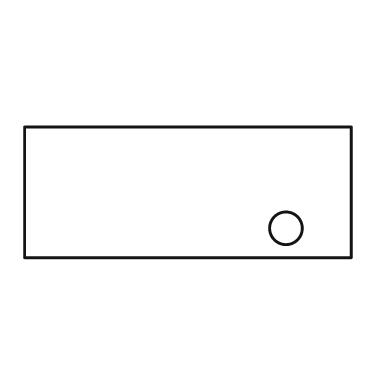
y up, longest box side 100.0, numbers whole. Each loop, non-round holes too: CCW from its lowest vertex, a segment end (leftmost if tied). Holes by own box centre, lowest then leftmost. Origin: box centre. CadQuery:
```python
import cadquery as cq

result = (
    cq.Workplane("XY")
    .moveTo(-50.0, -20.0)
    .lineTo(50.0, -20.0)
    .lineTo(50.0, 20.0)
    .lineTo(-50.0, 20.0)
    .close()
    .moveTo(30.0, -11.0)
    .circle(5.0)
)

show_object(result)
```